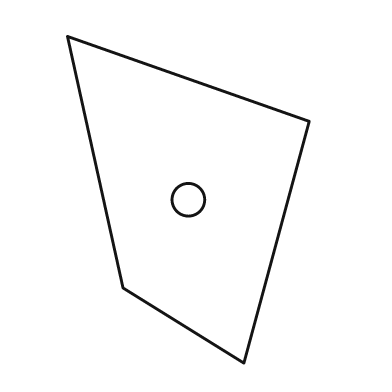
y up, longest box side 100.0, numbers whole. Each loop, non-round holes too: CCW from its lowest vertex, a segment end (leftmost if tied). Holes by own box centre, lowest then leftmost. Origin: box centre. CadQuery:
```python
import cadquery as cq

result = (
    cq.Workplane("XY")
    .moveTo(17.0, -50.0)
    .lineTo(37.0, 24.0)
    .lineTo(-37.0, 50.0)
    .lineTo(-20.0, -27.0)
    .close()
    .moveTo(0.0, 0.0)
    .circle(5.0)
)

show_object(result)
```